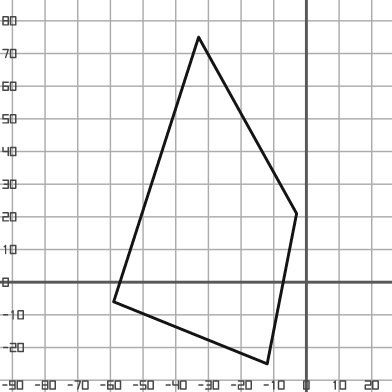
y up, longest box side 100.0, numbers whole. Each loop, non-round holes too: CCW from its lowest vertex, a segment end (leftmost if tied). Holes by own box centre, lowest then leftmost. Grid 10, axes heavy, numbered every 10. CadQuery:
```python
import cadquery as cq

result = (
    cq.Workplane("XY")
    .moveTo(-12.0, -25.0)
    .lineTo(-3.0, 21.0)
    .lineTo(-33.0, 75.0)
    .lineTo(-59.0, -6.0)
    .close()
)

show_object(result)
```